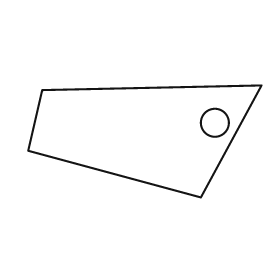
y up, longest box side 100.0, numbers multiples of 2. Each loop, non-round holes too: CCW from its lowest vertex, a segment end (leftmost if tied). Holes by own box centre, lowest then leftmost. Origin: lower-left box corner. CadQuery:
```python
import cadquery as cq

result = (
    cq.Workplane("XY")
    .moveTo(74.0, 0.0)
    .lineTo(100.0, 48.0)
    .lineTo(6.0, 46.0)
    .lineTo(0.0, 20.0)
    .close()
    .moveTo(80.0, 32.0)
    .circle(6.0)
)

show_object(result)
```